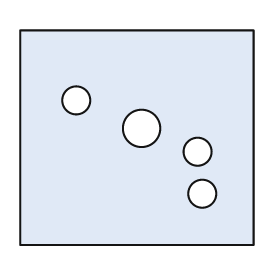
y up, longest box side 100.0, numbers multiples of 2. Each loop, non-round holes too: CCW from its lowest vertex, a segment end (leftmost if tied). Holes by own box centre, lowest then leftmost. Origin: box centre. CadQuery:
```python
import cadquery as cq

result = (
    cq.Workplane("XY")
    .moveTo(-50.0, -46.0)
    .lineTo(50.0, -46.0)
    .lineTo(50.0, 46.0)
    .lineTo(-50.0, 46.0)
    .close()
    .moveTo(28.0, -24.0)
    .circle(6.0)
    .moveTo(26.0, -6.0)
    .circle(6.0)
    .moveTo(2.0, 4.0)
    .circle(8.0)
    .moveTo(-26.0, 16.0)
    .circle(6.0)
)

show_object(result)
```